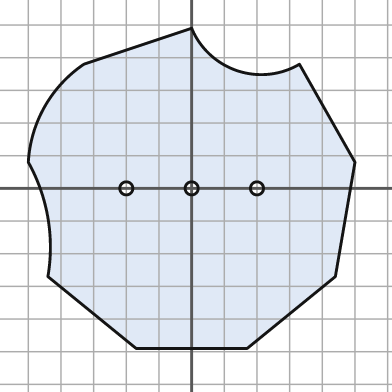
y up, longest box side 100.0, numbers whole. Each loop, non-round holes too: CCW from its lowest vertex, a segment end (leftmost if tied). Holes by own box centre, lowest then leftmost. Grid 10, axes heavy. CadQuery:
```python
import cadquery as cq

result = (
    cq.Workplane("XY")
    .moveTo(-17.0, -49.0)
    .lineTo(17.0, -49.0)
    .lineTo(44.0, -27.0)
    .lineTo(50.0, 8.0)
    .lineTo(33.0, 38.0)
    .threePointArc((14.0, 36.0), (0.0, 49.0))
    .lineTo(-33.0, 38.0)
    .threePointArc((-45.0, 25.0), (-50.0, 8.0))
    .threePointArc((-44.0, -9.0), (-44.0, -27.0))
    .close()
    .moveTo(-20.0, 0.0)
    .circle(2.0)
    .moveTo(0.0, 0.0)
    .circle(2.0)
    .moveTo(20.0, 0.0)
    .circle(2.0)
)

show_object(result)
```